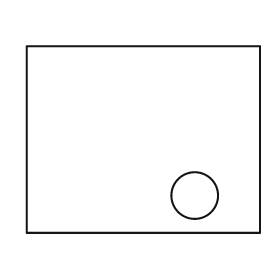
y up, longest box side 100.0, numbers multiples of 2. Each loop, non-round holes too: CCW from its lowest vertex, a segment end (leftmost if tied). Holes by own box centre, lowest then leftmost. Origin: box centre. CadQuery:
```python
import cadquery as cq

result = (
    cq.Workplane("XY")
    .moveTo(-50.0, -40.0)
    .lineTo(50.0, -40.0)
    .lineTo(50.0, 40.0)
    .lineTo(-50.0, 40.0)
    .close()
    .moveTo(22.0, -24.0)
    .circle(10.0)
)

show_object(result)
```